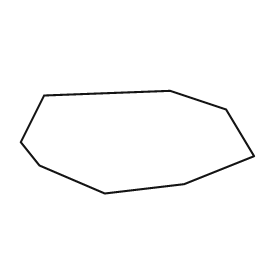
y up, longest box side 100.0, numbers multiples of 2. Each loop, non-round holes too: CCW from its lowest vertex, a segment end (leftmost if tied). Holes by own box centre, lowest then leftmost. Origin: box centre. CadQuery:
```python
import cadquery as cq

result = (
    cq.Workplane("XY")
    .moveTo(-14.0, -22.0)
    .lineTo(20.0, -18.0)
    .lineTo(50.0, -6.0)
    .lineTo(38.0, 14.0)
    .lineTo(14.0, 22.0)
    .lineTo(-40.0, 20.0)
    .lineTo(-50.0, 0.0)
    .lineTo(-42.0, -10.0)
    .close()
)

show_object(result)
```